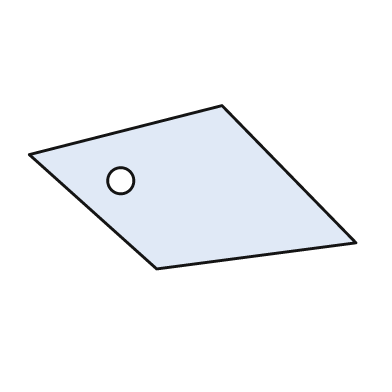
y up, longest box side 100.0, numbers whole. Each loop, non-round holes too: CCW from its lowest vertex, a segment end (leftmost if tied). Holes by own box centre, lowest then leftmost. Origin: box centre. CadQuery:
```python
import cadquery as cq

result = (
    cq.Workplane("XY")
    .moveTo(-11.0, -25.0)
    .lineTo(50.0, -17.0)
    .lineTo(9.0, 25.0)
    .lineTo(-50.0, 10.0)
    .close()
    .moveTo(-22.0, 2.0)
    .circle(4.0)
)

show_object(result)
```